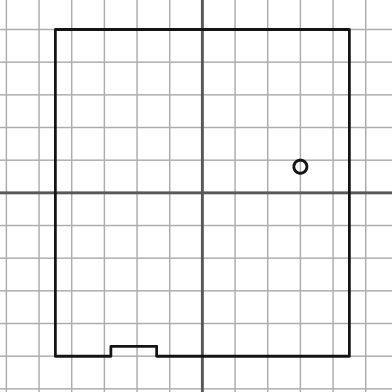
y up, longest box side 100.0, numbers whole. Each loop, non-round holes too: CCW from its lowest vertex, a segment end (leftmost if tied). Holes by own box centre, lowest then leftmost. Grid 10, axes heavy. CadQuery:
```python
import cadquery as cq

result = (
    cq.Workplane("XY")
    .moveTo(-45.0, -50.0)
    .lineTo(-28.0, -50.0)
    .lineTo(-28.0, -47.0)
    .lineTo(-14.0, -47.0)
    .lineTo(-14.0, -50.0)
    .lineTo(45.0, -50.0)
    .lineTo(45.0, 50.0)
    .lineTo(-45.0, 50.0)
    .close()
    .moveTo(30.0, 8.0)
    .circle(2.0)
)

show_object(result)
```